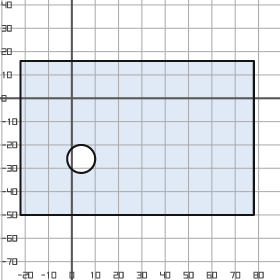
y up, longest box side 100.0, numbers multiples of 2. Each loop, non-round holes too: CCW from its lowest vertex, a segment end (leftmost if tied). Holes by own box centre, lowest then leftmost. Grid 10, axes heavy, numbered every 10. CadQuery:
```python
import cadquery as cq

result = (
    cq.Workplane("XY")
    .moveTo(-22.0, -50.0)
    .lineTo(78.0, -50.0)
    .lineTo(78.0, 16.0)
    .lineTo(-22.0, 16.0)
    .close()
    .moveTo(4.0, -26.0)
    .circle(6.0)
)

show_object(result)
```